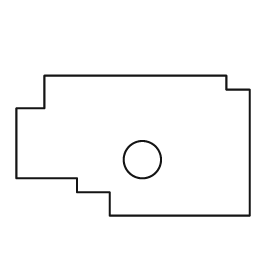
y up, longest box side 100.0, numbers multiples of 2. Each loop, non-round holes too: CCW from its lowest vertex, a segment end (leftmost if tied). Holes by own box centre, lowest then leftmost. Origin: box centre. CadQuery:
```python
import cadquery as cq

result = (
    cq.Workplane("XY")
    .moveTo(-10.0, -30.0)
    .lineTo(50.0, -30.0)
    .lineTo(50.0, 24.0)
    .lineTo(40.0, 24.0)
    .lineTo(40.0, 30.0)
    .lineTo(-38.0, 30.0)
    .lineTo(-38.0, 16.0)
    .lineTo(-50.0, 16.0)
    .lineTo(-50.0, -14.0)
    .lineTo(-24.0, -14.0)
    .lineTo(-24.0, -20.0)
    .lineTo(-10.0, -20.0)
    .close()
    .moveTo(4.0, -6.0)
    .circle(8.0)
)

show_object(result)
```